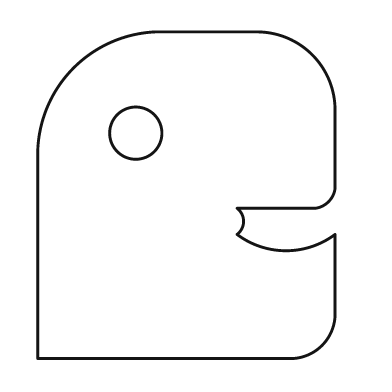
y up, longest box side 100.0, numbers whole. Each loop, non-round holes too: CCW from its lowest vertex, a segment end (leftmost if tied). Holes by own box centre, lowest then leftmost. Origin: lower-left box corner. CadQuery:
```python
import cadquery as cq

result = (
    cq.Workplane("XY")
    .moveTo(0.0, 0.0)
    .lineTo(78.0, 0.0)
    .threePointArc((87.0, 4.0), (91.0, 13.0))
    .lineTo(91.0, 38.0)
    .threePointArc((76.0, 33.0), (61.0, 38.0))
    .threePointArc((63.0, 42.0), (61.0, 46.0))
    .lineTo(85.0, 46.0)
    .threePointArc((89.0, 48.0), (91.0, 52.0))
    .lineTo(91.0, 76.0)
    .threePointArc((84.0, 93.0), (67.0, 100.0))
    .lineTo(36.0, 100.0)
    .threePointArc((11.0, 89.0), (0.0, 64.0))
    .close()
    .moveTo(30.0, 69.0)
    .circle(8.0)
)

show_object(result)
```